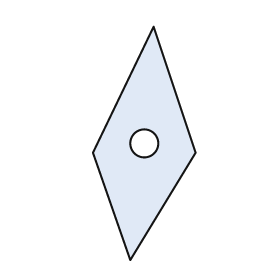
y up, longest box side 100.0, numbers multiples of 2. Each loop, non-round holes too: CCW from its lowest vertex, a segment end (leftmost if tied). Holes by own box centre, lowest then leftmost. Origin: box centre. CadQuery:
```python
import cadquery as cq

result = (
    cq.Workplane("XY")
    .moveTo(-6.0, -50.0)
    .lineTo(22.0, -4.0)
    .lineTo(4.0, 50.0)
    .lineTo(-22.0, -4.0)
    .close()
    .moveTo(0.0, 0.0)
    .circle(6.0)
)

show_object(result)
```